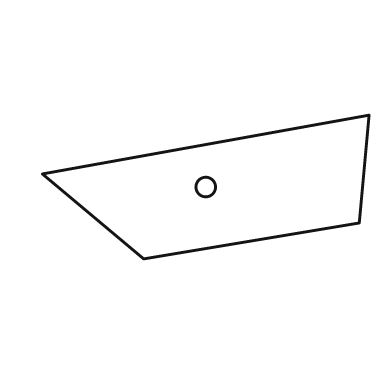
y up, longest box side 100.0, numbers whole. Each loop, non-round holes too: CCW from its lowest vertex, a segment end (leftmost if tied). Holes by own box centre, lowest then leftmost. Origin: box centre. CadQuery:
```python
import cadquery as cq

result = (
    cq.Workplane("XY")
    .moveTo(-19.0, -22.0)
    .lineTo(47.0, -11.0)
    .lineTo(50.0, 22.0)
    .lineTo(-50.0, 4.0)
    .close()
    .moveTo(0.0, 0.0)
    .circle(3.0)
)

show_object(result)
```